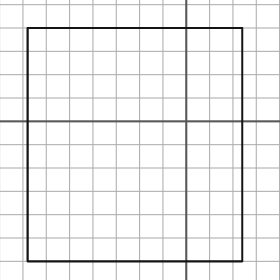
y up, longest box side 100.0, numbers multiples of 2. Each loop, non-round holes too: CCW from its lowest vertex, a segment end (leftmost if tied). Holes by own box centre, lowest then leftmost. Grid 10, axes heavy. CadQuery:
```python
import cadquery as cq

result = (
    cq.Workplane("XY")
    .moveTo(-68.0, -60.0)
    .lineTo(24.0, -60.0)
    .lineTo(24.0, 40.0)
    .lineTo(-68.0, 40.0)
    .close()
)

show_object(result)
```